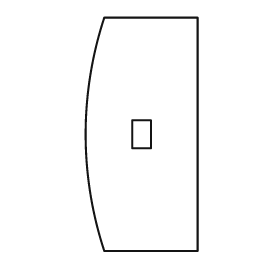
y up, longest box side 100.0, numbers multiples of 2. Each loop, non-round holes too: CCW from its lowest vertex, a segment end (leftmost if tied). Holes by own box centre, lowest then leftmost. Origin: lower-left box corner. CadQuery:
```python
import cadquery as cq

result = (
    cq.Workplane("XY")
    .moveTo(8.0, 0.0)
    .lineTo(48.0, 0.0)
    .lineTo(48.0, 100.0)
    .lineTo(8.0, 100.0)
    .threePointArc((0.0, 50.0), (8.0, 0.0))
    .close()
    .moveTo(20.0, 44.0)
    .lineTo(28.0, 44.0)
    .lineTo(28.0, 56.0)
    .lineTo(20.0, 56.0)
    .close()
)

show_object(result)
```